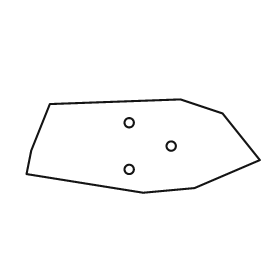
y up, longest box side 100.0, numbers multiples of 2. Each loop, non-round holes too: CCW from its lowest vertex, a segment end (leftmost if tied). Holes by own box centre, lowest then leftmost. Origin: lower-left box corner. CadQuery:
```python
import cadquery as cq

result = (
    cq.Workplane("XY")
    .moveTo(50.0, 0.0)
    .lineTo(72.0, 2.0)
    .lineTo(100.0, 14.0)
    .lineTo(84.0, 34.0)
    .lineTo(66.0, 40.0)
    .lineTo(10.0, 38.0)
    .lineTo(2.0, 18.0)
    .lineTo(0.0, 8.0)
    .close()
    .moveTo(44.0, 10.0)
    .circle(2.0)
    .moveTo(62.0, 20.0)
    .circle(2.0)
    .moveTo(44.0, 30.0)
    .circle(2.0)
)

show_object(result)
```